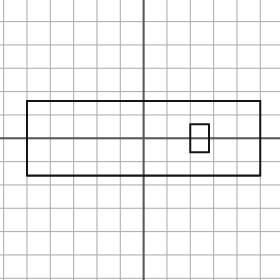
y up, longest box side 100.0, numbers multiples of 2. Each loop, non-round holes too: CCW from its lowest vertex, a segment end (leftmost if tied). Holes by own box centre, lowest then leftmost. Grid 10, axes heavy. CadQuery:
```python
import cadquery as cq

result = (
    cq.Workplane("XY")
    .moveTo(-50.0, -16.0)
    .lineTo(50.0, -16.0)
    .lineTo(50.0, 16.0)
    .lineTo(-50.0, 16.0)
    .close()
    .moveTo(20.0, -6.0)
    .lineTo(28.0, -6.0)
    .lineTo(28.0, 6.0)
    .lineTo(20.0, 6.0)
    .close()
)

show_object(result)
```